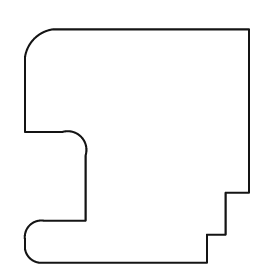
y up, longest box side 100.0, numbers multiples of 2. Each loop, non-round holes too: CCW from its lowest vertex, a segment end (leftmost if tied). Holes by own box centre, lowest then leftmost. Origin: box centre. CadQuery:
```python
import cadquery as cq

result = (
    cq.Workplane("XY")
    .moveTo(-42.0, -50.0)
    .lineTo(30.0, -50.0)
    .lineTo(30.0, -38.0)
    .lineTo(38.0, -38.0)
    .lineTo(38.0, -20.0)
    .lineTo(48.0, -20.0)
    .lineTo(48.0, 50.0)
    .lineTo(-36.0, 50.0)
    .threePointArc((-44.0, 46.0), (-48.0, 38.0))
    .lineTo(-48.0, 6.0)
    .lineTo(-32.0, 6.0)
    .threePointArc((-24.0, 4.0), (-22.0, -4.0))
    .lineTo(-22.0, -32.0)
    .lineTo(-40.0, -32.0)
    .threePointArc((-46.0, -34.0), (-48.0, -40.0))
    .lineTo(-48.0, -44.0)
    .threePointArc((-46.0, -48.0), (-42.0, -50.0))
    .close()
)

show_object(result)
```